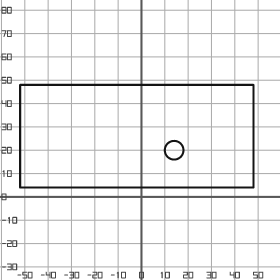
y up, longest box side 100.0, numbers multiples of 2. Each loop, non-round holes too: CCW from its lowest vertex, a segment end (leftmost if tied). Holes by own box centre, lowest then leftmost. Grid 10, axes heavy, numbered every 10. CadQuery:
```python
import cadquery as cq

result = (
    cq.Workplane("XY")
    .moveTo(-52.0, 4.0)
    .lineTo(48.0, 4.0)
    .lineTo(48.0, 48.0)
    .lineTo(-52.0, 48.0)
    .close()
    .moveTo(14.0, 20.0)
    .circle(4.0)
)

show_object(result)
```